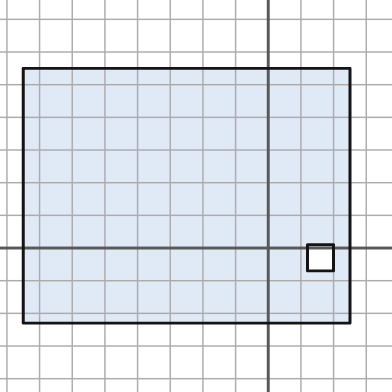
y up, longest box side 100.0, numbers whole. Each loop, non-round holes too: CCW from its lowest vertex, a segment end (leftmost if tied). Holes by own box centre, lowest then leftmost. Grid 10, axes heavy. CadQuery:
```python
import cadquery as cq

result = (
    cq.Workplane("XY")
    .moveTo(-75.0, -23.0)
    .lineTo(25.0, -23.0)
    .lineTo(25.0, 55.0)
    .lineTo(-75.0, 55.0)
    .close()
    .moveTo(12.0, -7.0)
    .lineTo(20.0, -7.0)
    .lineTo(20.0, 1.0)
    .lineTo(12.0, 1.0)
    .close()
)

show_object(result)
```